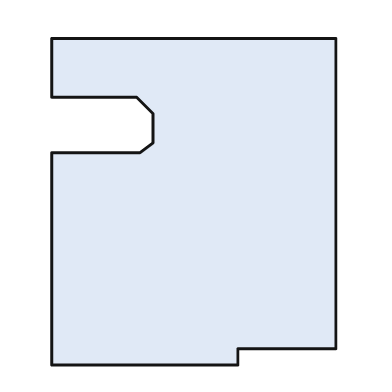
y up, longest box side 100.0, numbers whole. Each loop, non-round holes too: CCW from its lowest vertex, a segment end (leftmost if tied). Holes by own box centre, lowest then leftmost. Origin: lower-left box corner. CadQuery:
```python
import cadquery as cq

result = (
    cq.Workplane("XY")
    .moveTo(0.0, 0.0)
    .lineTo(57.0, 0.0)
    .lineTo(57.0, 5.0)
    .lineTo(87.0, 5.0)
    .lineTo(87.0, 100.0)
    .lineTo(0.0, 100.0)
    .lineTo(0.0, 82.0)
    .lineTo(26.0, 82.0)
    .lineTo(31.0, 77.0)
    .lineTo(31.0, 68.0)
    .lineTo(27.0, 65.0)
    .lineTo(0.0, 65.0)
    .close()
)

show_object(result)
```